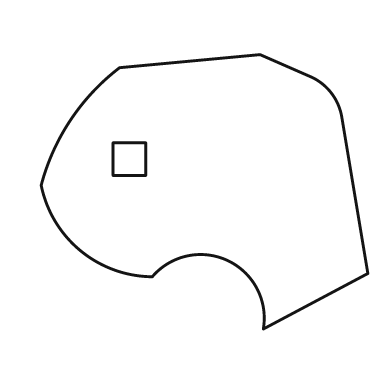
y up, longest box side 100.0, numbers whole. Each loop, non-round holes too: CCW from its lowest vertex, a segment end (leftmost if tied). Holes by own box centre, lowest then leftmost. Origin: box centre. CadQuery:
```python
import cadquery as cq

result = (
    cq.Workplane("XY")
    .moveTo(18.0, -42.0)
    .lineTo(50.0, -25.0)
    .lineTo(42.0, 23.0)
    .threePointArc((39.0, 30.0), (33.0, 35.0))
    .lineTo(17.0, 42.0)
    .lineTo(-26.0, 38.0)
    .threePointArc((-41.0, 22.0), (-50.0, 2.0))
    .threePointArc((-38.0, -18.0), (-16.0, -26.0))
    .threePointArc((7.0, -21.0), (18.0, -42.0))
    .close()
    .moveTo(-28.0, 5.0)
    .lineTo(-18.0, 5.0)
    .lineTo(-18.0, 15.0)
    .lineTo(-28.0, 15.0)
    .close()
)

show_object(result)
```